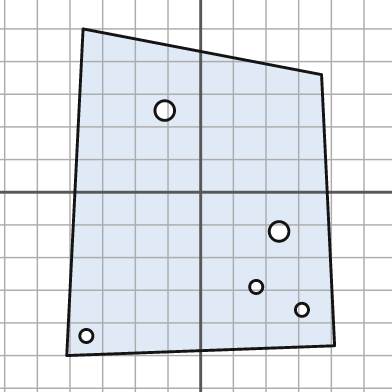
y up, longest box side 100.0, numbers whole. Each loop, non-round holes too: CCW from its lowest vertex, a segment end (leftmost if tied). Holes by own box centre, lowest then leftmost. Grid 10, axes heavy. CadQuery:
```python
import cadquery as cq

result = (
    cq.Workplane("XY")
    .moveTo(-41.0, -50.0)
    .lineTo(41.0, -47.0)
    .lineTo(37.0, 36.0)
    .lineTo(-36.0, 50.0)
    .close()
    .moveTo(-35.0, -44.0)
    .circle(2.0)
    .moveTo(31.0, -36.0)
    .circle(2.0)
    .moveTo(17.0, -29.0)
    .circle(2.0)
    .moveTo(24.0, -12.0)
    .circle(3.0)
    .moveTo(-11.0, 25.0)
    .circle(3.0)
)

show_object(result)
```